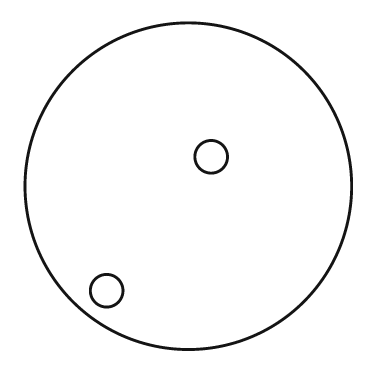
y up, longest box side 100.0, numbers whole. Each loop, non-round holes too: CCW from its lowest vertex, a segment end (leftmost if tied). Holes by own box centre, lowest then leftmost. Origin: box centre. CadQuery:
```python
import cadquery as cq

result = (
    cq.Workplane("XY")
    .moveTo(0.0, 0.0)
    .circle(50.0)
    .moveTo(-25.0, -32.0)
    .circle(5.0)
    .moveTo(7.0, 9.0)
    .circle(5.0)
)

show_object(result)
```